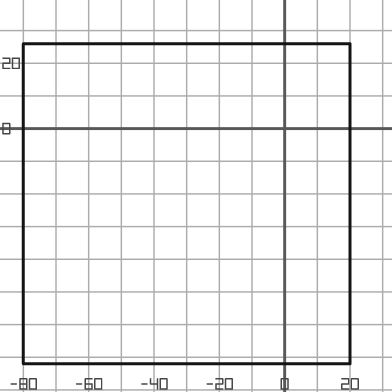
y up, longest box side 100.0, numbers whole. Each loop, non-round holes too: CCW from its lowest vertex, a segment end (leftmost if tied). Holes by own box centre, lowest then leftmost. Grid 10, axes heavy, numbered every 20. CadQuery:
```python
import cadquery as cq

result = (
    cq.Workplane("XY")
    .moveTo(-80.0, -72.0)
    .lineTo(20.0, -72.0)
    .lineTo(20.0, 26.0)
    .lineTo(-80.0, 26.0)
    .close()
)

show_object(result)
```